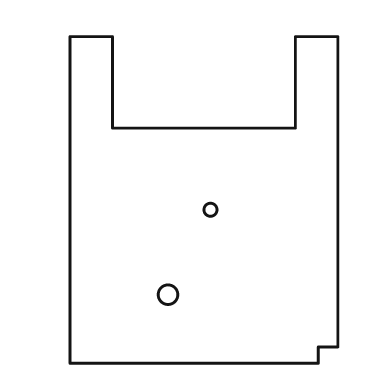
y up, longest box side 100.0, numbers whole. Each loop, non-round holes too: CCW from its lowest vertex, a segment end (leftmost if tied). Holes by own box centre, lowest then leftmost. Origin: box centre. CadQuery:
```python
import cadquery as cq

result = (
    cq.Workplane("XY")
    .moveTo(-41.0, -50.0)
    .lineTo(35.0, -50.0)
    .lineTo(35.0, -45.0)
    .lineTo(41.0, -45.0)
    .lineTo(41.0, 50.0)
    .lineTo(28.0, 50.0)
    .lineTo(28.0, 22.0)
    .lineTo(-28.0, 22.0)
    .lineTo(-28.0, 50.0)
    .lineTo(-41.0, 50.0)
    .close()
    .moveTo(-11.0, -29.0)
    .circle(3.0)
    .moveTo(2.0, -3.0)
    .circle(2.0)
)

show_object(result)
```